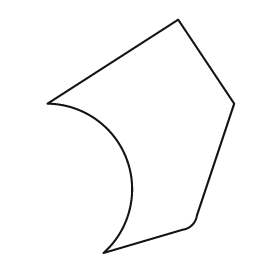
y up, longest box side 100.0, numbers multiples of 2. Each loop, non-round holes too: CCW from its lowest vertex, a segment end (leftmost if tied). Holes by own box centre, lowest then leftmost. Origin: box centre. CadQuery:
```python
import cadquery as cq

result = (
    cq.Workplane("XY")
    .moveTo(-16.0, -50.0)
    .lineTo(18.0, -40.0)
    .threePointArc((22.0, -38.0), (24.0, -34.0))
    .lineTo(40.0, 14.0)
    .lineTo(16.0, 50.0)
    .lineTo(-40.0, 14.0)
    .threePointArc((-6.0, -10.0), (-16.0, -50.0))
    .close()
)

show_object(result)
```